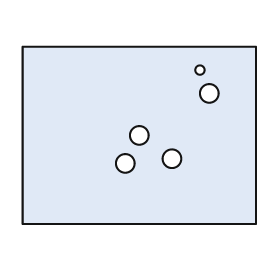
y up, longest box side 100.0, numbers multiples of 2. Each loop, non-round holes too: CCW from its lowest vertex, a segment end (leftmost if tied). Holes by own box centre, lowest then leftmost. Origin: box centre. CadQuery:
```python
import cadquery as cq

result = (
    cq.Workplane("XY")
    .moveTo(-50.0, -38.0)
    .lineTo(50.0, -38.0)
    .lineTo(50.0, 38.0)
    .lineTo(-50.0, 38.0)
    .close()
    .moveTo(-6.0, -12.0)
    .circle(4.0)
    .moveTo(14.0, -10.0)
    .circle(4.0)
    .moveTo(0.0, 0.0)
    .circle(4.0)
    .moveTo(30.0, 18.0)
    .circle(4.0)
    .moveTo(26.0, 28.0)
    .circle(2.0)
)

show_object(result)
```